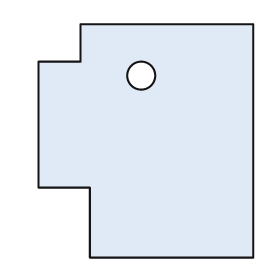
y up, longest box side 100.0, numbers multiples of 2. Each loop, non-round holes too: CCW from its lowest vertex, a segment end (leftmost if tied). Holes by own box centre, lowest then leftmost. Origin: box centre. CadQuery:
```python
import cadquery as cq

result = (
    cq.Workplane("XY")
    .moveTo(-24.0, -50.0)
    .lineTo(46.0, -50.0)
    .lineTo(46.0, 50.0)
    .lineTo(-28.0, 50.0)
    .lineTo(-28.0, 34.0)
    .lineTo(-46.0, 34.0)
    .lineTo(-46.0, -20.0)
    .lineTo(-24.0, -20.0)
    .close()
    .moveTo(-2.0, 28.0)
    .circle(6.0)
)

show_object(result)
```